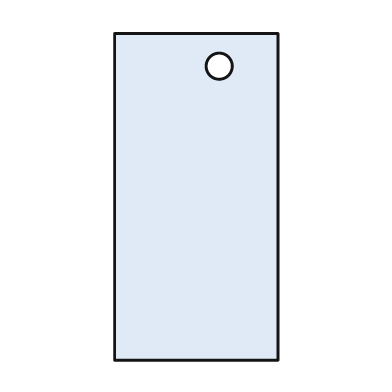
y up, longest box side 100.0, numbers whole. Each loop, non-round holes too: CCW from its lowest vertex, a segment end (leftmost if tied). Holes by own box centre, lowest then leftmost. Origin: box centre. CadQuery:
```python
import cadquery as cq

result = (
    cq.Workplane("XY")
    .moveTo(-25.0, -50.0)
    .lineTo(25.0, -50.0)
    .lineTo(25.0, 50.0)
    .lineTo(-25.0, 50.0)
    .close()
    .moveTo(7.0, 40.0)
    .circle(4.0)
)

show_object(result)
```